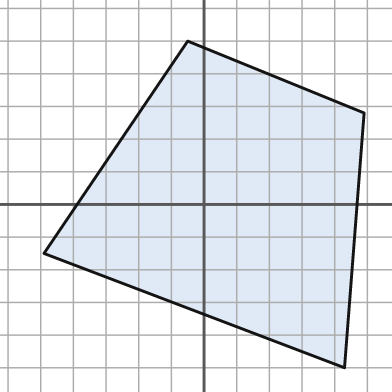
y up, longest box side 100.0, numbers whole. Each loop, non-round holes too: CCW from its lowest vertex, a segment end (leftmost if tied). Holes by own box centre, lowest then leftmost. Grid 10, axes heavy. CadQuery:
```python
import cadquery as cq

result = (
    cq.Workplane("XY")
    .moveTo(43.0, -50.0)
    .lineTo(49.0, 28.0)
    .lineTo(-5.0, 50.0)
    .lineTo(-49.0, -15.0)
    .close()
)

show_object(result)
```